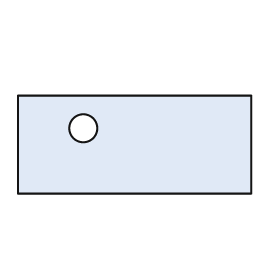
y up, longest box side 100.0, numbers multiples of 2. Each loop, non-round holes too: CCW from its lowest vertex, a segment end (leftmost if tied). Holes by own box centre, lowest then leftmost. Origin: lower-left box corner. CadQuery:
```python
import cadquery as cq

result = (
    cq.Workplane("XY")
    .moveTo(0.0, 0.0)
    .lineTo(100.0, 0.0)
    .lineTo(100.0, 42.0)
    .lineTo(0.0, 42.0)
    .close()
    .moveTo(28.0, 28.0)
    .circle(6.0)
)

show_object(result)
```